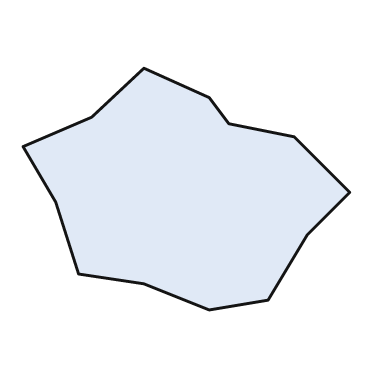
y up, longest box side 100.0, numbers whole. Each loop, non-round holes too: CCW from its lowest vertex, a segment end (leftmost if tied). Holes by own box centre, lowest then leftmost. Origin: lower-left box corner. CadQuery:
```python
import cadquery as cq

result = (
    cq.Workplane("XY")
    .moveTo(57.0, 0.0)
    .lineTo(75.0, 3.0)
    .lineTo(87.0, 23.0)
    .lineTo(100.0, 36.0)
    .lineTo(83.0, 53.0)
    .lineTo(63.0, 57.0)
    .lineTo(57.0, 65.0)
    .lineTo(37.0, 74.0)
    .lineTo(21.0, 59.0)
    .lineTo(0.0, 50.0)
    .lineTo(10.0, 33.0)
    .lineTo(17.0, 11.0)
    .lineTo(37.0, 8.0)
    .close()
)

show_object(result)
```